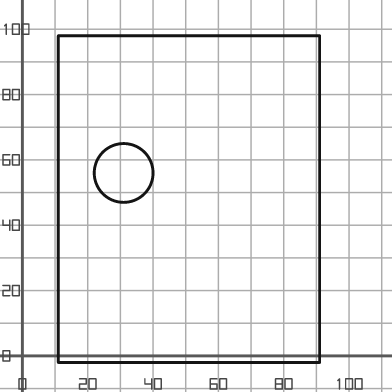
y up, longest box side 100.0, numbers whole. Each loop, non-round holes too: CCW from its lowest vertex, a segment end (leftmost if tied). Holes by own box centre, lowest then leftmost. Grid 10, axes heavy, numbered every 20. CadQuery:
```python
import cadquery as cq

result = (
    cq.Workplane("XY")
    .moveTo(11.0, -2.0)
    .lineTo(91.0, -2.0)
    .lineTo(91.0, 98.0)
    .lineTo(11.0, 98.0)
    .close()
    .moveTo(31.0, 56.0)
    .circle(9.0)
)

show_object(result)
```